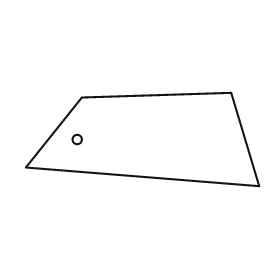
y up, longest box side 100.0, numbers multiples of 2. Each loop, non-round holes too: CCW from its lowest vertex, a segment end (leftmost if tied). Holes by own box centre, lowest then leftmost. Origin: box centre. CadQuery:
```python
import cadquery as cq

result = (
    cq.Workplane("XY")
    .moveTo(50.0, -20.0)
    .lineTo(38.0, 20.0)
    .lineTo(-26.0, 18.0)
    .lineTo(-50.0, -12.0)
    .close()
    .moveTo(-28.0, 0.0)
    .circle(2.0)
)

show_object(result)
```